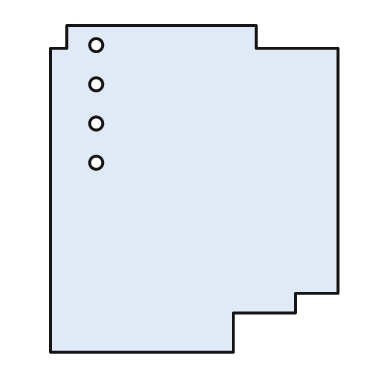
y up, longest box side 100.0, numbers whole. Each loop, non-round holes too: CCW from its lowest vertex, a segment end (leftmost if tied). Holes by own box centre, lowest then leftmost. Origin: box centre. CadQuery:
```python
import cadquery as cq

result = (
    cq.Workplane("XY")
    .moveTo(-44.0, -50.0)
    .lineTo(12.0, -50.0)
    .lineTo(12.0, -38.0)
    .lineTo(31.0, -38.0)
    .lineTo(31.0, -32.0)
    .lineTo(44.0, -32.0)
    .lineTo(44.0, 43.0)
    .lineTo(19.0, 43.0)
    .lineTo(19.0, 50.0)
    .lineTo(-39.0, 50.0)
    .lineTo(-39.0, 43.0)
    .lineTo(-44.0, 43.0)
    .close()
    .moveTo(-30.0, 8.0)
    .circle(2.0)
    .moveTo(-30.0, 20.0)
    .circle(2.0)
    .moveTo(-30.0, 32.0)
    .circle(2.0)
    .moveTo(-30.0, 44.0)
    .circle(2.0)
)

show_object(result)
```